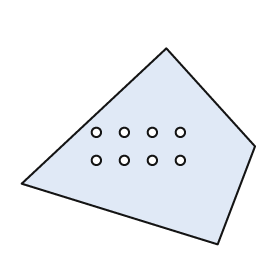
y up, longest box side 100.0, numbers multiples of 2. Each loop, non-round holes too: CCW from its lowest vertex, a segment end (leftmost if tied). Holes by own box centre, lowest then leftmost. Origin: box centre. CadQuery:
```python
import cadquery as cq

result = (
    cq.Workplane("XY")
    .moveTo(34.0, -42.0)
    .lineTo(50.0, 0.0)
    .lineTo(12.0, 42.0)
    .lineTo(-50.0, -16.0)
    .close()
    .moveTo(-18.0, -6.0)
    .circle(2.0)
    .moveTo(-6.0, -6.0)
    .circle(2.0)
    .moveTo(6.0, -6.0)
    .circle(2.0)
    .moveTo(18.0, -6.0)
    .circle(2.0)
    .moveTo(-18.0, 6.0)
    .circle(2.0)
    .moveTo(-6.0, 6.0)
    .circle(2.0)
    .moveTo(6.0, 6.0)
    .circle(2.0)
    .moveTo(18.0, 6.0)
    .circle(2.0)
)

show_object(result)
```